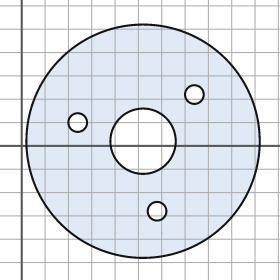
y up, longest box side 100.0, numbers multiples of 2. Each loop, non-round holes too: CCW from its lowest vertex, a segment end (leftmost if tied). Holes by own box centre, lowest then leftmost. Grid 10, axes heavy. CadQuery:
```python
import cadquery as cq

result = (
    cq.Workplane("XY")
    .moveTo(52.0, 2.0)
    .circle(50.0)
    .moveTo(58.0, -28.0)
    .circle(4.0)
    .moveTo(52.0, 2.0)
    .circle(14.0)
    .moveTo(24.0, 10.0)
    .circle(4.0)
    .moveTo(74.0, 22.0)
    .circle(4.0)
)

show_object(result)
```